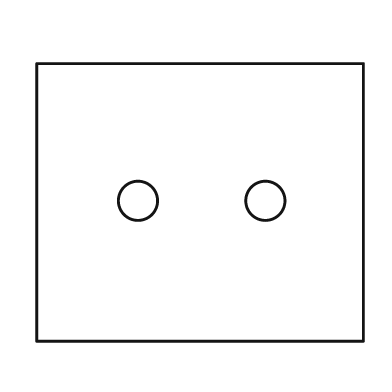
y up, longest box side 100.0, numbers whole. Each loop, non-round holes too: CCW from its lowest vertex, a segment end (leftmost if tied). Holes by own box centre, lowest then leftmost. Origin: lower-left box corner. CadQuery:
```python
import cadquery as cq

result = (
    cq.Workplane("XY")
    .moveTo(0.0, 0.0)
    .lineTo(100.0, 0.0)
    .lineTo(100.0, 85.0)
    .lineTo(0.0, 85.0)
    .close()
    .moveTo(31.0, 43.0)
    .circle(6.0)
    .moveTo(70.0, 43.0)
    .circle(6.0)
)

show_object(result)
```